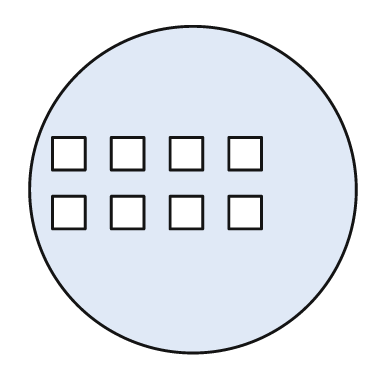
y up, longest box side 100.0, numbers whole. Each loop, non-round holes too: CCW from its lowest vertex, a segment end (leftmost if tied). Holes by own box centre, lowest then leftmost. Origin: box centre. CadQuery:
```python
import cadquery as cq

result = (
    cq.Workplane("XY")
    .moveTo(0.0, 0.0)
    .circle(50.0)
    .moveTo(-43.0, -12.0)
    .lineTo(-33.0, -12.0)
    .lineTo(-33.0, -2.0)
    .lineTo(-43.0, -2.0)
    .close()
    .moveTo(-25.0, -12.0)
    .lineTo(-15.0, -12.0)
    .lineTo(-15.0, -2.0)
    .lineTo(-25.0, -2.0)
    .close()
    .moveTo(-7.0, -12.0)
    .lineTo(3.0, -12.0)
    .lineTo(3.0, -2.0)
    .lineTo(-7.0, -2.0)
    .close()
    .moveTo(11.0, -12.0)
    .lineTo(21.0, -12.0)
    .lineTo(21.0, -2.0)
    .lineTo(11.0, -2.0)
    .close()
    .moveTo(-43.0, 6.0)
    .lineTo(-33.0, 6.0)
    .lineTo(-33.0, 16.0)
    .lineTo(-43.0, 16.0)
    .close()
    .moveTo(-25.0, 6.0)
    .lineTo(-15.0, 6.0)
    .lineTo(-15.0, 16.0)
    .lineTo(-25.0, 16.0)
    .close()
    .moveTo(-7.0, 6.0)
    .lineTo(3.0, 6.0)
    .lineTo(3.0, 16.0)
    .lineTo(-7.0, 16.0)
    .close()
    .moveTo(11.0, 6.0)
    .lineTo(21.0, 6.0)
    .lineTo(21.0, 16.0)
    .lineTo(11.0, 16.0)
    .close()
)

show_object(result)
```